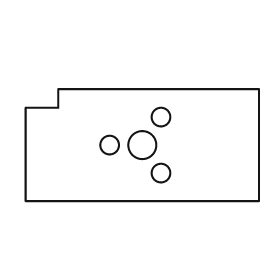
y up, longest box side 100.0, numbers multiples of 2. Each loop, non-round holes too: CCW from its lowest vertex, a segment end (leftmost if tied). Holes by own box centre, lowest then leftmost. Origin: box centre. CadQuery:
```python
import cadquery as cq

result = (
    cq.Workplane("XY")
    .moveTo(-50.0, -24.0)
    .lineTo(50.0, -24.0)
    .lineTo(50.0, 24.0)
    .lineTo(-36.0, 24.0)
    .lineTo(-36.0, 16.0)
    .lineTo(-50.0, 16.0)
    .close()
    .moveTo(8.0, -12.0)
    .circle(4.0)
    .moveTo(-14.0, 0.0)
    .circle(4.0)
    .moveTo(0.0, 0.0)
    .circle(6.0)
    .moveTo(8.0, 12.0)
    .circle(4.0)
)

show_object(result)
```